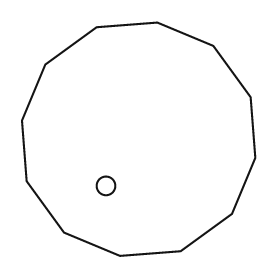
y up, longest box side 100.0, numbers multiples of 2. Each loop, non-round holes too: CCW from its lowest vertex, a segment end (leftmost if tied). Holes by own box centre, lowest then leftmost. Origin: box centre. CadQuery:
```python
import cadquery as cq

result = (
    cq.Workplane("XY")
    .moveTo(-8.0, -50.0)
    .lineTo(18.0, -48.0)
    .lineTo(40.0, -32.0)
    .lineTo(50.0, -8.0)
    .lineTo(48.0, 18.0)
    .lineTo(32.0, 40.0)
    .lineTo(8.0, 50.0)
    .lineTo(-18.0, 48.0)
    .lineTo(-40.0, 32.0)
    .lineTo(-50.0, 8.0)
    .lineTo(-48.0, -18.0)
    .lineTo(-32.0, -40.0)
    .close()
    .moveTo(-14.0, -20.0)
    .circle(4.0)
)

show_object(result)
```